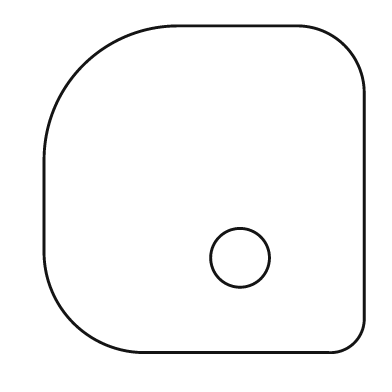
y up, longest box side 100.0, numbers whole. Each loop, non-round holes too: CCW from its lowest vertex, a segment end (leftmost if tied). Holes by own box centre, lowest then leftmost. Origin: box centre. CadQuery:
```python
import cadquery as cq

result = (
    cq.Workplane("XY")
    .moveTo(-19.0, -50.0)
    .lineTo(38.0, -50.0)
    .threePointArc((46.0, -47.0), (49.0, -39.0))
    .lineTo(49.0, 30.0)
    .threePointArc((43.0, 44.0), (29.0, 50.0))
    .lineTo(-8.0, 50.0)
    .threePointArc((-37.0, 38.0), (-49.0, 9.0))
    .lineTo(-49.0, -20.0)
    .threePointArc((-40.0, -41.0), (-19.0, -50.0))
    .close()
    .moveTo(11.0, -21.0)
    .circle(9.0)
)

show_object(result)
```